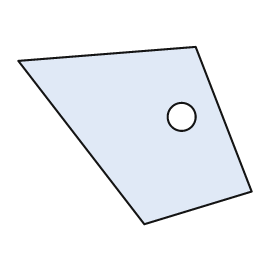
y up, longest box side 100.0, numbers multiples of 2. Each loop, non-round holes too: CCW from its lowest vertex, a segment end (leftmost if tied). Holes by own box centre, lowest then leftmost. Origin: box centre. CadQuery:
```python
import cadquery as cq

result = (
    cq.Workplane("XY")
    .moveTo(4.0, -38.0)
    .lineTo(50.0, -24.0)
    .lineTo(26.0, 38.0)
    .lineTo(-50.0, 32.0)
    .close()
    .moveTo(20.0, 8.0)
    .circle(6.0)
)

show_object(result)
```